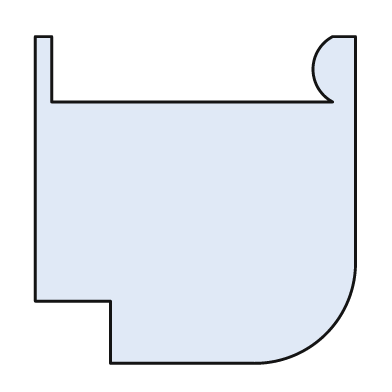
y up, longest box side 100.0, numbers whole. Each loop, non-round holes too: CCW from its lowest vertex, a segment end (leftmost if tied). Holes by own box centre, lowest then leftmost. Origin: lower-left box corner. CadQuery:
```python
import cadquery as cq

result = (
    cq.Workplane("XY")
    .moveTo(23.0, 0.0)
    .lineTo(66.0, 0.0)
    .threePointArc((89.0, 9.0), (98.0, 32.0))
    .lineTo(98.0, 100.0)
    .lineTo(91.0, 100.0)
    .threePointArc((85.0, 90.0), (91.0, 80.0))
    .lineTo(5.0, 80.0)
    .lineTo(5.0, 100.0)
    .lineTo(0.0, 100.0)
    .lineTo(0.0, 19.0)
    .lineTo(23.0, 19.0)
    .close()
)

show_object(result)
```